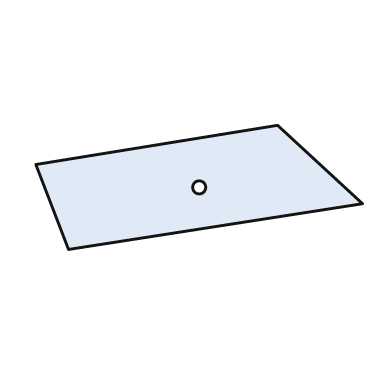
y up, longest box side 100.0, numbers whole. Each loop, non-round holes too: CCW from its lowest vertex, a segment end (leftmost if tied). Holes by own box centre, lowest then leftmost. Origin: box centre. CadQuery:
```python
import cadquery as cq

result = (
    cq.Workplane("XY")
    .moveTo(-40.0, -19.0)
    .lineTo(50.0, -5.0)
    .lineTo(24.0, 19.0)
    .lineTo(-50.0, 7.0)
    .close()
    .moveTo(0.0, 0.0)
    .circle(2.0)
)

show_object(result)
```